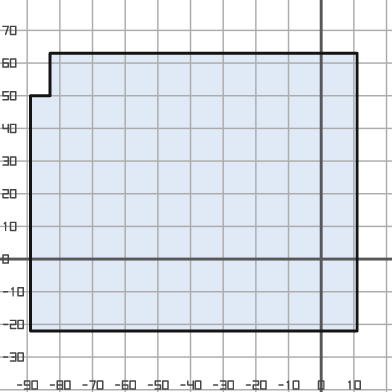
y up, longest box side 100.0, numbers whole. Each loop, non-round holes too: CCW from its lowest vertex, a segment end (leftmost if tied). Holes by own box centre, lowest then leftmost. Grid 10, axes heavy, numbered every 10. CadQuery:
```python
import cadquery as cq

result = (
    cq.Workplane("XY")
    .moveTo(-89.0, -22.0)
    .lineTo(11.0, -22.0)
    .lineTo(11.0, 63.0)
    .lineTo(-83.0, 63.0)
    .lineTo(-83.0, 50.0)
    .lineTo(-89.0, 50.0)
    .close()
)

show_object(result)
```